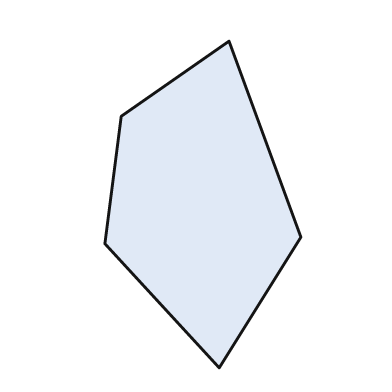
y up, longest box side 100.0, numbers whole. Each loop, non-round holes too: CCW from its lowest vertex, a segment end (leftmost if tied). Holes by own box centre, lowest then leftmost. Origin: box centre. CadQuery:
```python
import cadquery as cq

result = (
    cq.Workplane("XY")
    .moveTo(5.0, -50.0)
    .lineTo(30.0, -10.0)
    .lineTo(8.0, 50.0)
    .lineTo(-25.0, 27.0)
    .lineTo(-30.0, -12.0)
    .close()
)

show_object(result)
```